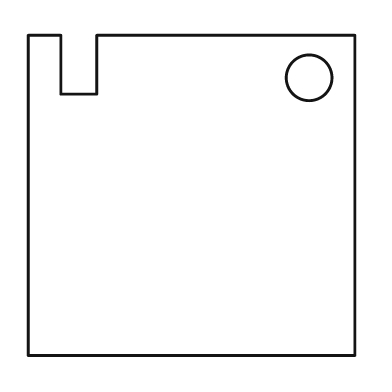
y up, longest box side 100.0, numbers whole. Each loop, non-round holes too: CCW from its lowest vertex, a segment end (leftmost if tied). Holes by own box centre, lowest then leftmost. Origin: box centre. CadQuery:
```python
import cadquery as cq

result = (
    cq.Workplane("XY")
    .moveTo(-50.0, -49.0)
    .lineTo(50.0, -49.0)
    .lineTo(50.0, 49.0)
    .lineTo(-29.0, 49.0)
    .lineTo(-29.0, 31.0)
    .lineTo(-40.0, 31.0)
    .lineTo(-40.0, 49.0)
    .lineTo(-50.0, 49.0)
    .close()
    .moveTo(36.0, 36.0)
    .circle(7.0)
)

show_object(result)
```